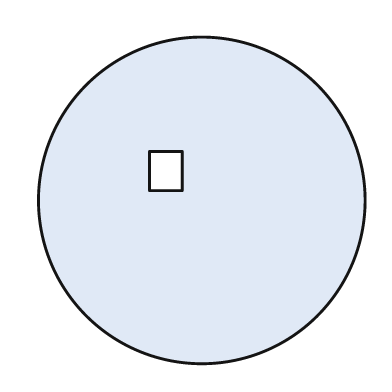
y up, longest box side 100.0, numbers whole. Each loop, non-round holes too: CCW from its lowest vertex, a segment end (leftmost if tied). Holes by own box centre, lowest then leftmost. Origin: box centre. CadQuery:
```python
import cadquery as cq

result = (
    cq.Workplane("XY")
    .moveTo(0.0, 0.0)
    .circle(50.0)
    .moveTo(-16.0, 3.0)
    .lineTo(-6.0, 3.0)
    .lineTo(-6.0, 15.0)
    .lineTo(-16.0, 15.0)
    .close()
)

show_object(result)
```